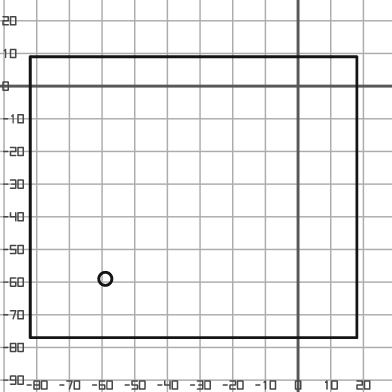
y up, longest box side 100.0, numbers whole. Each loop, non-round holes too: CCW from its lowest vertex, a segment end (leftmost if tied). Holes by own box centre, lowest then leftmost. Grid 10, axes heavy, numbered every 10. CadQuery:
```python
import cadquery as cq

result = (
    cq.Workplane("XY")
    .moveTo(-82.0, -77.0)
    .lineTo(18.0, -77.0)
    .lineTo(18.0, 9.0)
    .lineTo(-82.0, 9.0)
    .close()
    .moveTo(-59.0, -59.0)
    .circle(2.0)
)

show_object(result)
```